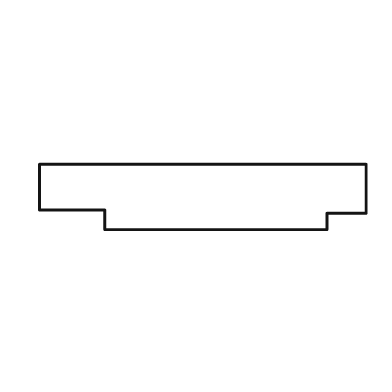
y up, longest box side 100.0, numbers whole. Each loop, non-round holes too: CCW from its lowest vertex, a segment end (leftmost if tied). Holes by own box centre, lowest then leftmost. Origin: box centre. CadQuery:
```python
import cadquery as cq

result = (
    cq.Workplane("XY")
    .moveTo(-30.0, -10.0)
    .lineTo(38.0, -10.0)
    .lineTo(38.0, -5.0)
    .lineTo(50.0, -5.0)
    .lineTo(50.0, 10.0)
    .lineTo(-50.0, 10.0)
    .lineTo(-50.0, -4.0)
    .lineTo(-30.0, -4.0)
    .close()
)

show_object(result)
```